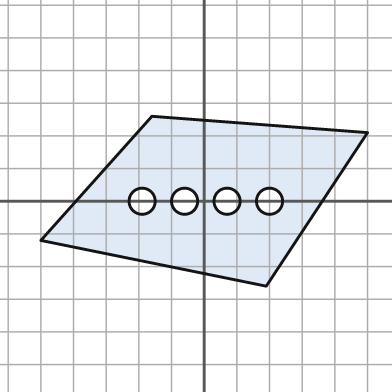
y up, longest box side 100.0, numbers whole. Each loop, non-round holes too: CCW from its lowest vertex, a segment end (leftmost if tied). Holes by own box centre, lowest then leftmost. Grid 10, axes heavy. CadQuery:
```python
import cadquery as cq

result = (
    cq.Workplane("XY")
    .moveTo(19.0, -26.0)
    .lineTo(50.0, 21.0)
    .lineTo(-16.0, 26.0)
    .lineTo(-50.0, -12.0)
    .close()
    .moveTo(-19.0, 0.0)
    .circle(4.0)
    .moveTo(-6.0, 0.0)
    .circle(4.0)
    .moveTo(7.0, 0.0)
    .circle(4.0)
    .moveTo(20.0, 0.0)
    .circle(4.0)
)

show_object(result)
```